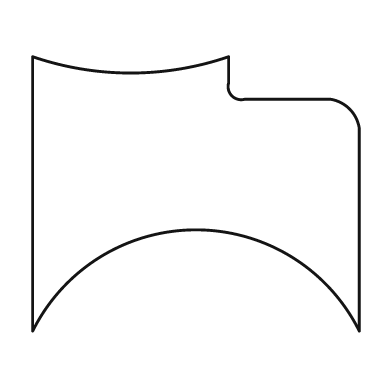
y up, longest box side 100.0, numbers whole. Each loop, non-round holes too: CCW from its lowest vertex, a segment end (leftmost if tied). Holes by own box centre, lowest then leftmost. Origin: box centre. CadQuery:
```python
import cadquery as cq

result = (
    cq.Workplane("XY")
    .moveTo(-50.0, -42.0)
    .threePointArc((0.0, -11.0), (50.0, -42.0))
    .lineTo(50.0, 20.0)
    .threePointArc((47.0, 26.0), (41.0, 29.0))
    .lineTo(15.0, 29.0)
    .threePointArc((11.0, 30.0), (10.0, 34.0))
    .lineTo(10.0, 42.0)
    .threePointArc((-20.0, 37.0), (-50.0, 42.0))
    .close()
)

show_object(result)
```